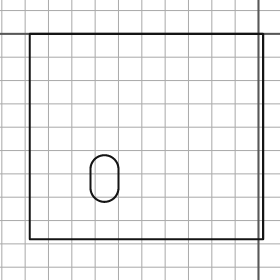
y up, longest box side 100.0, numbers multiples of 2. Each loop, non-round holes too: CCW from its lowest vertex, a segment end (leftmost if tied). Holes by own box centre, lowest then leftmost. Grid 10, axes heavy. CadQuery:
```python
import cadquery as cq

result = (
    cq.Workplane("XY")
    .moveTo(-98.0, -88.0)
    .lineTo(2.0, -88.0)
    .lineTo(2.0, 0.0)
    .lineTo(-98.0, 0.0)
    .close()
    .moveTo(-72.0, -66.0)
    .threePointArc((-66.0, -72.0), (-60.0, -66.0))
    .lineTo(-60.0, -58.0)
    .threePointArc((-66.0, -52.0), (-72.0, -58.0))
    .close()
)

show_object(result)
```